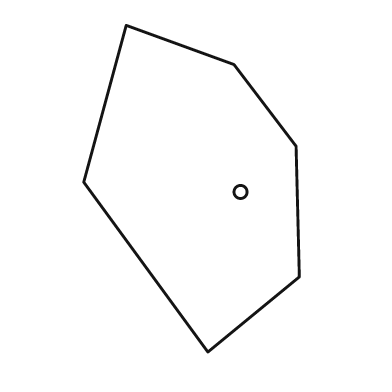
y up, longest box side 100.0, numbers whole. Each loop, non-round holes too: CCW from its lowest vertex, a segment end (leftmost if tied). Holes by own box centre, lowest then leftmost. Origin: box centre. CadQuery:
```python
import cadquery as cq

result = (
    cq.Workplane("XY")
    .moveTo(5.0, -50.0)
    .lineTo(33.0, -27.0)
    .lineTo(32.0, 13.0)
    .lineTo(13.0, 38.0)
    .lineTo(-20.0, 50.0)
    .lineTo(-33.0, 2.0)
    .close()
    .moveTo(15.0, -1.0)
    .circle(2.0)
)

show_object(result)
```